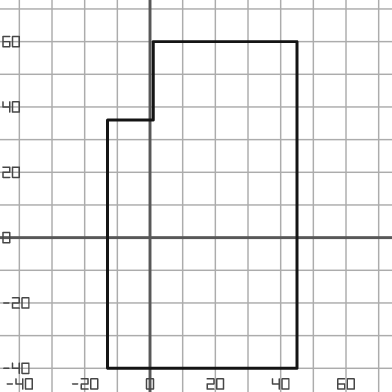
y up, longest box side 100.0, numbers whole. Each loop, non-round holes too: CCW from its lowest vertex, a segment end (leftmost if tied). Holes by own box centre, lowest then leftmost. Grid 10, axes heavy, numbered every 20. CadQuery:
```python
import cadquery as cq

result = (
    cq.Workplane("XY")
    .moveTo(-13.0, -40.0)
    .lineTo(45.0, -40.0)
    .lineTo(45.0, 60.0)
    .lineTo(1.0, 60.0)
    .lineTo(1.0, 36.0)
    .lineTo(-13.0, 36.0)
    .close()
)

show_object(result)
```